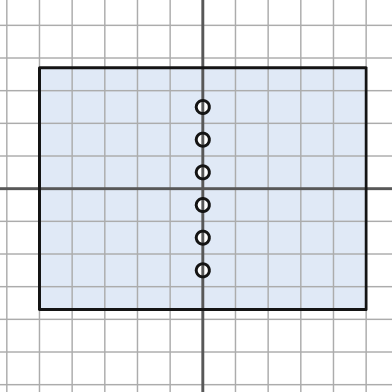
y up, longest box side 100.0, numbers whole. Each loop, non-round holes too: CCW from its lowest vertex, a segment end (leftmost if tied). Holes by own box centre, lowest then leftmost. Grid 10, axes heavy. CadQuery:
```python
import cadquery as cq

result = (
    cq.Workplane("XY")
    .moveTo(-50.0, -37.0)
    .lineTo(50.0, -37.0)
    .lineTo(50.0, 37.0)
    .lineTo(-50.0, 37.0)
    .close()
    .moveTo(0.0, -25.0)
    .circle(2.0)
    .moveTo(0.0, -15.0)
    .circle(2.0)
    .moveTo(0.0, -5.0)
    .circle(2.0)
    .moveTo(0.0, 5.0)
    .circle(2.0)
    .moveTo(0.0, 15.0)
    .circle(2.0)
    .moveTo(0.0, 25.0)
    .circle(2.0)
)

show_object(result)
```